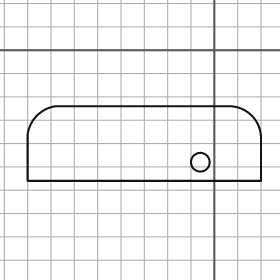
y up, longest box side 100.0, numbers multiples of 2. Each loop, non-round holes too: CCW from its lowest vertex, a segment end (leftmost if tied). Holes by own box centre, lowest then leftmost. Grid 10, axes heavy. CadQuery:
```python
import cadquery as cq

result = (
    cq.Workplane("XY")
    .moveTo(-80.0, -56.0)
    .lineTo(20.0, -56.0)
    .lineTo(20.0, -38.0)
    .threePointArc((16.0, -28.0), (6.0, -24.0))
    .lineTo(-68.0, -24.0)
    .threePointArc((-76.0, -28.0), (-80.0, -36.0))
    .close()
    .moveTo(-6.0, -48.0)
    .circle(4.0)
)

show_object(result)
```